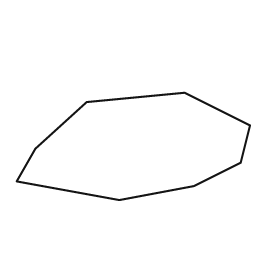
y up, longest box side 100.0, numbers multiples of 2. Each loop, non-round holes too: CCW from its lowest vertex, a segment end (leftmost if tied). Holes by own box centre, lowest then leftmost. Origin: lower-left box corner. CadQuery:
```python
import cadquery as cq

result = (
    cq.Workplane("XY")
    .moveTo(44.0, 0.0)
    .lineTo(76.0, 6.0)
    .lineTo(96.0, 16.0)
    .lineTo(100.0, 32.0)
    .lineTo(72.0, 46.0)
    .lineTo(30.0, 42.0)
    .lineTo(8.0, 22.0)
    .lineTo(0.0, 8.0)
    .close()
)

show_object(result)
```